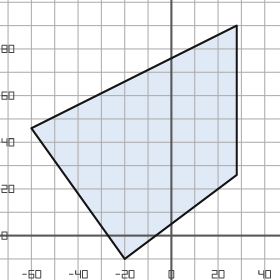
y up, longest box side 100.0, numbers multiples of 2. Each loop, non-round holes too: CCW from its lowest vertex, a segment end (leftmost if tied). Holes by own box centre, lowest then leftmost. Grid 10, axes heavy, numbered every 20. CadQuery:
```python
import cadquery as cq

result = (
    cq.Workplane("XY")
    .moveTo(-20.0, -10.0)
    .lineTo(28.0, 26.0)
    .lineTo(28.0, 90.0)
    .lineTo(-60.0, 46.0)
    .close()
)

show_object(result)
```